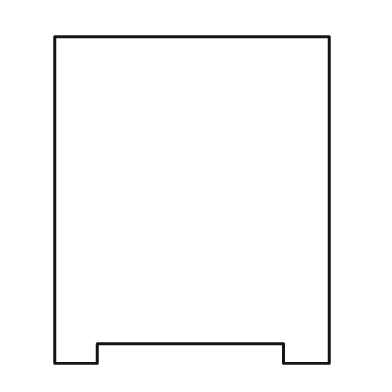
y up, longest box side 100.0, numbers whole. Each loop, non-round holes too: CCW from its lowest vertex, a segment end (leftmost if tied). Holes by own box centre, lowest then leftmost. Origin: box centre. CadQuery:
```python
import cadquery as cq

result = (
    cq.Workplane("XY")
    .moveTo(-42.0, -50.0)
    .lineTo(-29.0, -50.0)
    .lineTo(-29.0, -44.0)
    .lineTo(28.0, -44.0)
    .lineTo(28.0, -50.0)
    .lineTo(42.0, -50.0)
    .lineTo(42.0, 50.0)
    .lineTo(-42.0, 50.0)
    .close()
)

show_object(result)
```